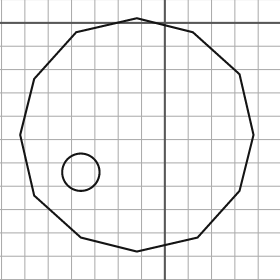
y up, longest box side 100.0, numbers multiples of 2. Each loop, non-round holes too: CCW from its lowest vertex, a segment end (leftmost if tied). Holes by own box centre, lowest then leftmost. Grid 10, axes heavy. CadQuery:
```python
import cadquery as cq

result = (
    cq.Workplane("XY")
    .moveTo(-12.0, -98.0)
    .lineTo(14.0, -92.0)
    .lineTo(32.0, -72.0)
    .lineTo(38.0, -48.0)
    .lineTo(32.0, -22.0)
    .lineTo(12.0, -4.0)
    .lineTo(-12.0, 2.0)
    .lineTo(-38.0, -4.0)
    .lineTo(-56.0, -24.0)
    .lineTo(-62.0, -48.0)
    .lineTo(-56.0, -74.0)
    .lineTo(-36.0, -92.0)
    .close()
    .moveTo(-36.0, -64.0)
    .circle(8.0)
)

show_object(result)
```